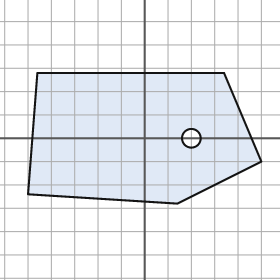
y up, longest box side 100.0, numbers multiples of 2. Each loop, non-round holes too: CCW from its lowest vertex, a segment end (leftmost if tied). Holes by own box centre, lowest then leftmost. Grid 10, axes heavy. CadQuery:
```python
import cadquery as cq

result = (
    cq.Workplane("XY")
    .moveTo(14.0, -28.0)
    .lineTo(50.0, -10.0)
    .lineTo(34.0, 28.0)
    .lineTo(-46.0, 28.0)
    .lineTo(-50.0, -24.0)
    .close()
    .moveTo(20.0, 0.0)
    .circle(4.0)
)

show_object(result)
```